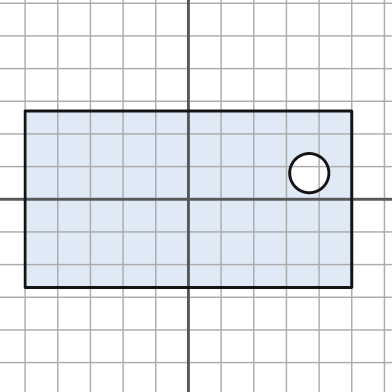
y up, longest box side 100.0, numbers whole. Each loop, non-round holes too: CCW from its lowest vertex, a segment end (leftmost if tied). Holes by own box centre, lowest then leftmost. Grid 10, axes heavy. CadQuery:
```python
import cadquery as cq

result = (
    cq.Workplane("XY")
    .moveTo(-50.0, -27.0)
    .lineTo(50.0, -27.0)
    .lineTo(50.0, 27.0)
    .lineTo(-50.0, 27.0)
    .close()
    .moveTo(37.0, 8.0)
    .circle(6.0)
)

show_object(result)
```